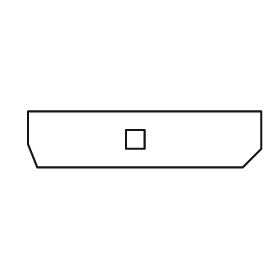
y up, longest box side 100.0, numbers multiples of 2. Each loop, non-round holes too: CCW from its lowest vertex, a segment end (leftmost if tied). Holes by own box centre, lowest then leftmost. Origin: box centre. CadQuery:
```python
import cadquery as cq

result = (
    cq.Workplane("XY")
    .moveTo(-46.0, -12.0)
    .lineTo(42.0, -12.0)
    .lineTo(50.0, -4.0)
    .lineTo(50.0, 12.0)
    .lineTo(-50.0, 12.0)
    .lineTo(-50.0, -2.0)
    .close()
    .moveTo(-8.0, -4.0)
    .lineTo(0.0, -4.0)
    .lineTo(0.0, 4.0)
    .lineTo(-8.0, 4.0)
    .close()
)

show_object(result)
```